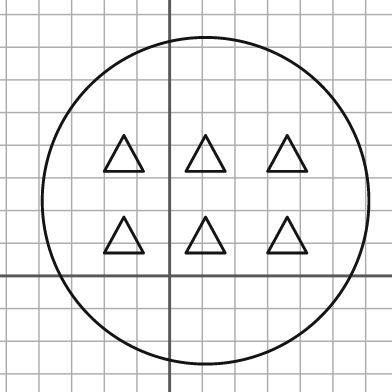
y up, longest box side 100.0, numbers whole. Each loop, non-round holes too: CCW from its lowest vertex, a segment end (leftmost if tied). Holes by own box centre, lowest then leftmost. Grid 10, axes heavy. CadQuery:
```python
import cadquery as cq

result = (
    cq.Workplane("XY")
    .moveTo(11.0, 23.0)
    .circle(50.0)
    .moveTo(-20.0, 7.0)
    .lineTo(-8.0, 7.0)
    .lineTo(-14.0, 18.0)
    .close()
    .moveTo(5.0, 7.0)
    .lineTo(17.0, 7.0)
    .lineTo(11.0, 18.0)
    .close()
    .moveTo(30.0, 7.0)
    .lineTo(42.0, 7.0)
    .lineTo(36.0, 18.0)
    .close()
    .moveTo(-20.0, 32.0)
    .lineTo(-8.0, 32.0)
    .lineTo(-14.0, 43.0)
    .close()
    .moveTo(5.0, 32.0)
    .lineTo(17.0, 32.0)
    .lineTo(11.0, 43.0)
    .close()
    .moveTo(30.0, 32.0)
    .lineTo(42.0, 32.0)
    .lineTo(36.0, 43.0)
    .close()
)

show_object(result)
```